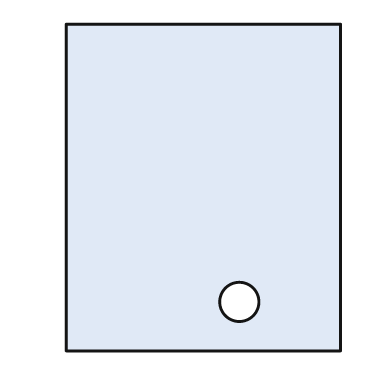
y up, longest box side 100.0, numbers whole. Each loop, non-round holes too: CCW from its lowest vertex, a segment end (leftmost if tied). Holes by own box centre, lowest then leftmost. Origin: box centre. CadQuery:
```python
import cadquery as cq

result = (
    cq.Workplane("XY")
    .moveTo(-42.0, -50.0)
    .lineTo(42.0, -50.0)
    .lineTo(42.0, 50.0)
    .lineTo(-42.0, 50.0)
    .close()
    .moveTo(11.0, -35.0)
    .circle(6.0)
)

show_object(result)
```